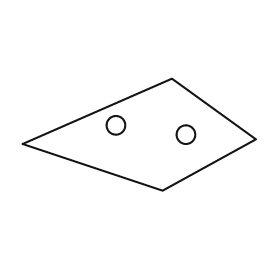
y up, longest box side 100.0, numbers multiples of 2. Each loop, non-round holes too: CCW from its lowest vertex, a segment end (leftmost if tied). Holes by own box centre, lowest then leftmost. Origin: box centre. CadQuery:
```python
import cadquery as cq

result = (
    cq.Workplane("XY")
    .moveTo(10.0, -24.0)
    .lineTo(50.0, -2.0)
    .lineTo(14.0, 24.0)
    .lineTo(-50.0, -4.0)
    .close()
    .moveTo(20.0, 0.0)
    .circle(4.0)
    .moveTo(-10.0, 4.0)
    .circle(4.0)
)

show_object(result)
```